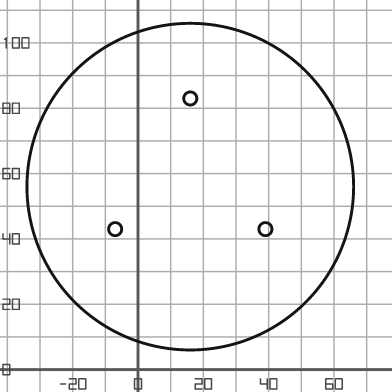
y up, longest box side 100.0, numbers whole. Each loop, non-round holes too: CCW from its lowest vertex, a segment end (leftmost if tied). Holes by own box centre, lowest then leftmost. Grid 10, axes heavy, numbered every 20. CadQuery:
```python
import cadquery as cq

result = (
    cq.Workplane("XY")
    .moveTo(16.0, 56.0)
    .circle(50.0)
    .moveTo(-7.0, 43.0)
    .circle(2.0)
    .moveTo(39.0, 43.0)
    .circle(2.0)
    .moveTo(16.0, 83.0)
    .circle(2.0)
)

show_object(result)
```